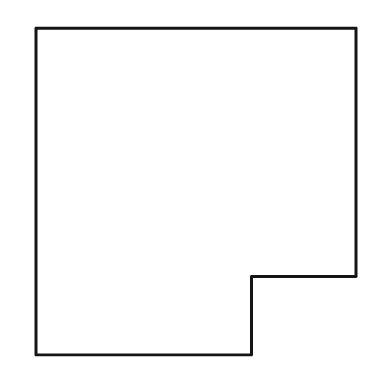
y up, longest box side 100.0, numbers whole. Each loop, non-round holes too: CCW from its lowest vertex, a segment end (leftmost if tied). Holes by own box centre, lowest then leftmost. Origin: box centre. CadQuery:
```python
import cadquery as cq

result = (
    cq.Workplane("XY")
    .moveTo(-49.0, -50.0)
    .lineTo(17.0, -50.0)
    .lineTo(17.0, -26.0)
    .lineTo(49.0, -26.0)
    .lineTo(49.0, 50.0)
    .lineTo(-49.0, 50.0)
    .close()
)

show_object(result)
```